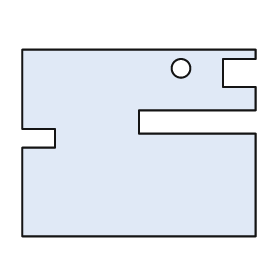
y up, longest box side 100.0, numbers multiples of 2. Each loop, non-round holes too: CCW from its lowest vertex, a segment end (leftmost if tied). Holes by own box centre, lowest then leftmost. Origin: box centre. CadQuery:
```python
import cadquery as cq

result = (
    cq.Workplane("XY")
    .moveTo(-50.0, -40.0)
    .lineTo(50.0, -40.0)
    .lineTo(50.0, 4.0)
    .lineTo(0.0, 4.0)
    .lineTo(0.0, 14.0)
    .lineTo(50.0, 14.0)
    .lineTo(50.0, 24.0)
    .lineTo(36.0, 24.0)
    .lineTo(36.0, 36.0)
    .lineTo(50.0, 36.0)
    .lineTo(50.0, 40.0)
    .lineTo(-50.0, 40.0)
    .lineTo(-50.0, 6.0)
    .lineTo(-36.0, 6.0)
    .lineTo(-36.0, -2.0)
    .lineTo(-50.0, -2.0)
    .close()
    .moveTo(18.0, 32.0)
    .circle(4.0)
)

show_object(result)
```